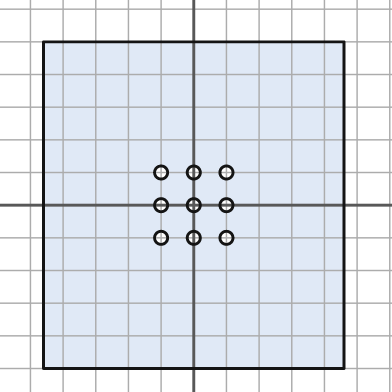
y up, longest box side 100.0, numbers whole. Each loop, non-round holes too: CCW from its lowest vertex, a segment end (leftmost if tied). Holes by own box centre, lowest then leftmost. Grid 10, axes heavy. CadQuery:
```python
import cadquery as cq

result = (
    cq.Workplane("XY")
    .moveTo(-46.0, -50.0)
    .lineTo(46.0, -50.0)
    .lineTo(46.0, 50.0)
    .lineTo(-46.0, 50.0)
    .close()
    .moveTo(-10.0, -10.0)
    .circle(2.0)
    .moveTo(0.0, -10.0)
    .circle(2.0)
    .moveTo(10.0, -10.0)
    .circle(2.0)
    .moveTo(-10.0, 0.0)
    .circle(2.0)
    .moveTo(0.0, 0.0)
    .circle(2.0)
    .moveTo(10.0, 0.0)
    .circle(2.0)
    .moveTo(-10.0, 10.0)
    .circle(2.0)
    .moveTo(0.0, 10.0)
    .circle(2.0)
    .moveTo(10.0, 10.0)
    .circle(2.0)
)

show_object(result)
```